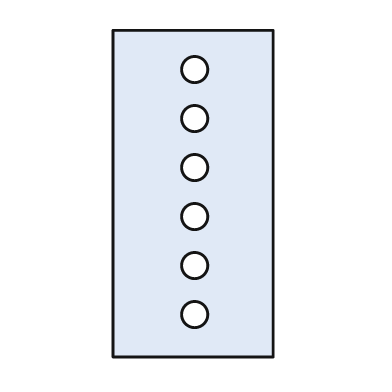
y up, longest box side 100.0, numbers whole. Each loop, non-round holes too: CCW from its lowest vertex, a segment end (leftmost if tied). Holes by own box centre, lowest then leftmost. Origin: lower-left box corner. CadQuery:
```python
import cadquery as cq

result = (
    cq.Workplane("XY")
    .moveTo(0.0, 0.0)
    .lineTo(49.0, 0.0)
    .lineTo(49.0, 100.0)
    .lineTo(0.0, 100.0)
    .close()
    .moveTo(25.0, 13.0)
    .circle(4.0)
    .moveTo(25.0, 28.0)
    .circle(4.0)
    .moveTo(25.0, 43.0)
    .circle(4.0)
    .moveTo(25.0, 58.0)
    .circle(4.0)
    .moveTo(25.0, 73.0)
    .circle(4.0)
    .moveTo(25.0, 88.0)
    .circle(4.0)
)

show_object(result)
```